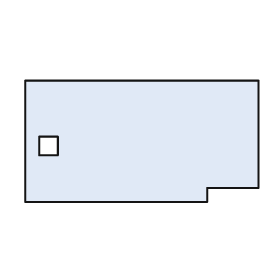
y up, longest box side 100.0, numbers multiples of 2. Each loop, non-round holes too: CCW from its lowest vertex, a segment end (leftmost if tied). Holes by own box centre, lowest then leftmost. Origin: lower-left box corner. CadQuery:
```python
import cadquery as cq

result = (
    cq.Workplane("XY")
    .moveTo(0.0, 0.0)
    .lineTo(78.0, 0.0)
    .lineTo(78.0, 6.0)
    .lineTo(100.0, 6.0)
    .lineTo(100.0, 52.0)
    .lineTo(0.0, 52.0)
    .close()
    .moveTo(6.0, 20.0)
    .lineTo(14.0, 20.0)
    .lineTo(14.0, 28.0)
    .lineTo(6.0, 28.0)
    .close()
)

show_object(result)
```